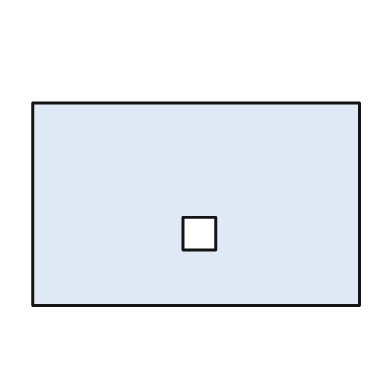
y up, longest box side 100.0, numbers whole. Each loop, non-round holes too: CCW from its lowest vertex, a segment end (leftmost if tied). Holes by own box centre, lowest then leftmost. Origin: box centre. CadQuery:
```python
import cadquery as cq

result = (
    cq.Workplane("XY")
    .moveTo(-50.0, -31.0)
    .lineTo(50.0, -31.0)
    .lineTo(50.0, 31.0)
    .lineTo(-50.0, 31.0)
    .close()
    .moveTo(-4.0, -14.0)
    .lineTo(6.0, -14.0)
    .lineTo(6.0, -4.0)
    .lineTo(-4.0, -4.0)
    .close()
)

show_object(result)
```